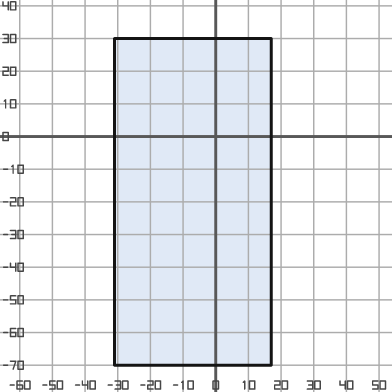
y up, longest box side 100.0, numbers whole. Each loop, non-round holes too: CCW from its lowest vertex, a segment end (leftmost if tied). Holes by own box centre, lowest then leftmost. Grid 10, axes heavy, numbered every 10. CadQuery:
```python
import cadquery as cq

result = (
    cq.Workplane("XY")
    .moveTo(-31.0, -70.0)
    .lineTo(17.0, -70.0)
    .lineTo(17.0, 30.0)
    .lineTo(-31.0, 30.0)
    .close()
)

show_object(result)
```